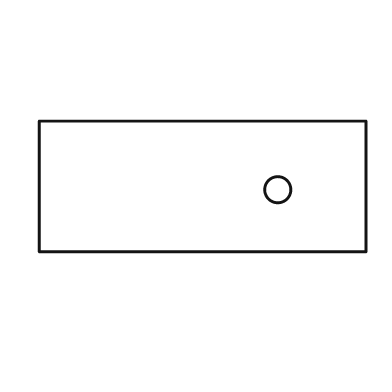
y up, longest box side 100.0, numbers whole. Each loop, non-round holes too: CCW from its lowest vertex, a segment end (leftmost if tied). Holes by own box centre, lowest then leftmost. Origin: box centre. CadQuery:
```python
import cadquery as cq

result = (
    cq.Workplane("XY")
    .moveTo(-50.0, -20.0)
    .lineTo(50.0, -20.0)
    .lineTo(50.0, 20.0)
    .lineTo(-50.0, 20.0)
    .close()
    .moveTo(23.0, -1.0)
    .circle(4.0)
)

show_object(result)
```